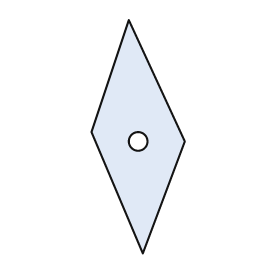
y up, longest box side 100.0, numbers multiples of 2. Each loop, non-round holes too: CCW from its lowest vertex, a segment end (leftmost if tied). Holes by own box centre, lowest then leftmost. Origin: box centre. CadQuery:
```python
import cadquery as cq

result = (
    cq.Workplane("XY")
    .moveTo(2.0, -50.0)
    .lineTo(20.0, -2.0)
    .lineTo(-4.0, 50.0)
    .lineTo(-20.0, 2.0)
    .close()
    .moveTo(0.0, -2.0)
    .circle(4.0)
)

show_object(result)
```